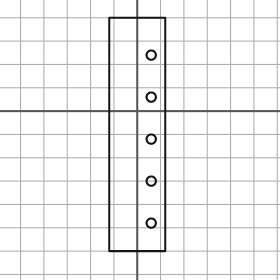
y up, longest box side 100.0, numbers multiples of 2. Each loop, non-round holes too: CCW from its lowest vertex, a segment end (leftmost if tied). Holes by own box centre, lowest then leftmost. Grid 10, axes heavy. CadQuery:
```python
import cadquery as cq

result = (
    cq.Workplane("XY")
    .moveTo(-12.0, -60.0)
    .lineTo(12.0, -60.0)
    .lineTo(12.0, 40.0)
    .lineTo(-12.0, 40.0)
    .close()
    .moveTo(6.0, -48.0)
    .circle(2.0)
    .moveTo(6.0, -30.0)
    .circle(2.0)
    .moveTo(6.0, -12.0)
    .circle(2.0)
    .moveTo(6.0, 6.0)
    .circle(2.0)
    .moveTo(6.0, 24.0)
    .circle(2.0)
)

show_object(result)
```